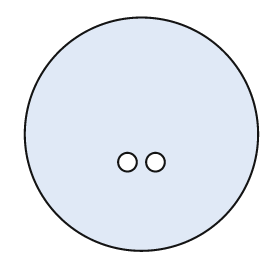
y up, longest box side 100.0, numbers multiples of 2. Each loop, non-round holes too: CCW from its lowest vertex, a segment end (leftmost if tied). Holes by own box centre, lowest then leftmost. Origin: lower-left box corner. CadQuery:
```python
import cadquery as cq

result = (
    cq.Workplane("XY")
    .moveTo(50.0, 50.0)
    .circle(50.0)
    .moveTo(44.0, 38.0)
    .circle(4.0)
    .moveTo(56.0, 38.0)
    .circle(4.0)
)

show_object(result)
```